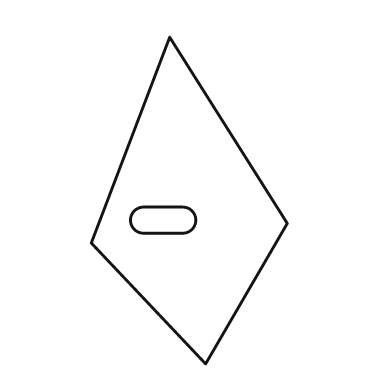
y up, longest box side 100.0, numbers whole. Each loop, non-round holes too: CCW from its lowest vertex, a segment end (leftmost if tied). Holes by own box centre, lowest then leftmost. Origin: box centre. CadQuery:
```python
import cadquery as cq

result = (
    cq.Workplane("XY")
    .moveTo(5.0, -50.0)
    .lineTo(30.0, -7.0)
    .lineTo(-6.0, 50.0)
    .lineTo(-30.0, -13.0)
    .close()
    .moveTo(-14.0, -10.0)
    .lineTo(-2.0, -10.0)
    .threePointArc((2.0, -6.0), (-2.0, -2.0))
    .lineTo(-14.0, -2.0)
    .threePointArc((-18.0, -6.0), (-14.0, -10.0))
    .close()
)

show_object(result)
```